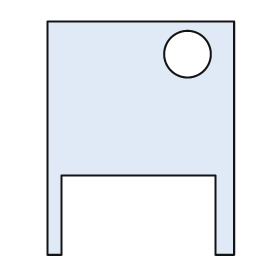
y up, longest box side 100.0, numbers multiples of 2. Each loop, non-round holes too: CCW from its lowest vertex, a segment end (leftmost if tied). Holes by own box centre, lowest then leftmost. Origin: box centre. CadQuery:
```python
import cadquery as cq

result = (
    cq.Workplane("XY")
    .moveTo(-40.0, -50.0)
    .lineTo(-34.0, -50.0)
    .lineTo(-34.0, -16.0)
    .lineTo(32.0, -16.0)
    .lineTo(32.0, -50.0)
    .lineTo(40.0, -50.0)
    .lineTo(40.0, 50.0)
    .lineTo(-40.0, 50.0)
    .close()
    .moveTo(20.0, 36.0)
    .circle(10.0)
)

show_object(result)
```